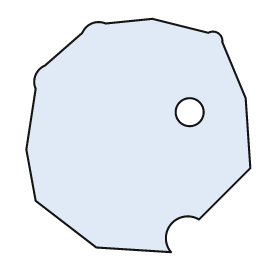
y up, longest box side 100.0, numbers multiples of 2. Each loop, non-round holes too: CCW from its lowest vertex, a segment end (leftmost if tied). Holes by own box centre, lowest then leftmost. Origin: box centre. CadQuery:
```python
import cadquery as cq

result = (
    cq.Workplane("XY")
    .moveTo(14.0, -50.0)
    .threePointArc((14.0, -38.0), (26.0, -36.0))
    .lineTo(48.0, -14.0)
    .lineTo(46.0, 16.0)
    .lineTo(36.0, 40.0)
    .threePointArc((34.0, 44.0), (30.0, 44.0))
    .lineTo(6.0, 50.0)
    .lineTo(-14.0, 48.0)
    .threePointArc((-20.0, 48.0), (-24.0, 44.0))
    .lineTo(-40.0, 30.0)
    .threePointArc((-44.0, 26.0), (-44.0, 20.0))
    .lineTo(-48.0, -6.0)
    .lineTo(-44.0, -28.0)
    .lineTo(-18.0, -48.0)
    .close()
    .moveTo(22.0, 10.0)
    .circle(6.0)
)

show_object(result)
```